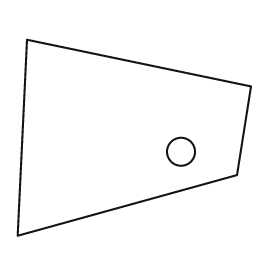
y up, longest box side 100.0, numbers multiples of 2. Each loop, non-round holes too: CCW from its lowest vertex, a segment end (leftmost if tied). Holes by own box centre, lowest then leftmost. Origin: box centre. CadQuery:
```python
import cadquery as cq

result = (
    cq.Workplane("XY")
    .moveTo(-50.0, -42.0)
    .lineTo(44.0, -16.0)
    .lineTo(50.0, 22.0)
    .lineTo(-46.0, 42.0)
    .close()
    .moveTo(20.0, -6.0)
    .circle(6.0)
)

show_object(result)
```